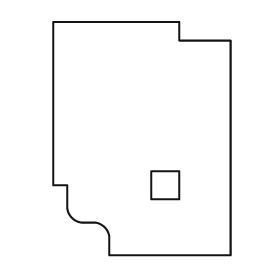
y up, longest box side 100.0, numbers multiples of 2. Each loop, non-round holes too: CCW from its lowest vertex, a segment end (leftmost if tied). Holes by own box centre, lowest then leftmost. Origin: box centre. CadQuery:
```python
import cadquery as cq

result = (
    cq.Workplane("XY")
    .moveTo(-14.0, -50.0)
    .lineTo(38.0, -50.0)
    .lineTo(38.0, 42.0)
    .lineTo(16.0, 42.0)
    .lineTo(16.0, 50.0)
    .lineTo(-38.0, 50.0)
    .lineTo(-38.0, -20.0)
    .lineTo(-32.0, -20.0)
    .lineTo(-32.0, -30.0)
    .threePointArc((-30.0, -34.0), (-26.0, -36.0))
    .lineTo(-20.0, -36.0)
    .threePointArc((-16.0, -38.0), (-14.0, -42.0))
    .close()
    .moveTo(4.0, -26.0)
    .lineTo(16.0, -26.0)
    .lineTo(16.0, -14.0)
    .lineTo(4.0, -14.0)
    .close()
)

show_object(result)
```